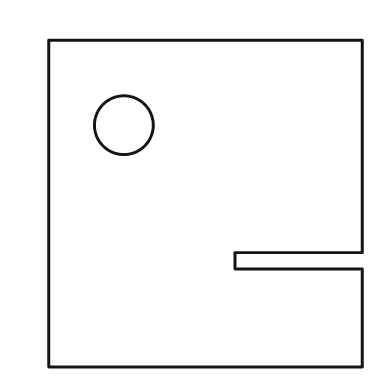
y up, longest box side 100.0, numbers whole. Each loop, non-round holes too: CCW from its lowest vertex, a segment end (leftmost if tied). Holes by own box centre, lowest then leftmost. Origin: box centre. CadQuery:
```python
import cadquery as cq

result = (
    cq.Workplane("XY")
    .moveTo(-48.0, -50.0)
    .lineTo(48.0, -50.0)
    .lineTo(48.0, -20.0)
    .lineTo(9.0, -20.0)
    .lineTo(9.0, -15.0)
    .lineTo(48.0, -15.0)
    .lineTo(48.0, 50.0)
    .lineTo(-48.0, 50.0)
    .close()
    .moveTo(-25.0, 24.0)
    .circle(9.0)
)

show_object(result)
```